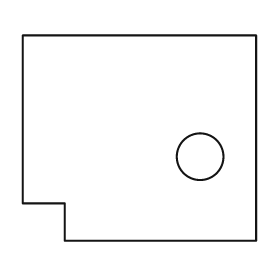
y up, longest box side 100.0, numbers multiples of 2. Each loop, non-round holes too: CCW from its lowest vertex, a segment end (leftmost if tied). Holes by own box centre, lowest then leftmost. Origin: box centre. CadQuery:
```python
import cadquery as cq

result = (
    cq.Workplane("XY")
    .moveTo(-32.0, -44.0)
    .lineTo(50.0, -44.0)
    .lineTo(50.0, 44.0)
    .lineTo(-50.0, 44.0)
    .lineTo(-50.0, -28.0)
    .lineTo(-32.0, -28.0)
    .close()
    .moveTo(26.0, -8.0)
    .circle(10.0)
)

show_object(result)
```